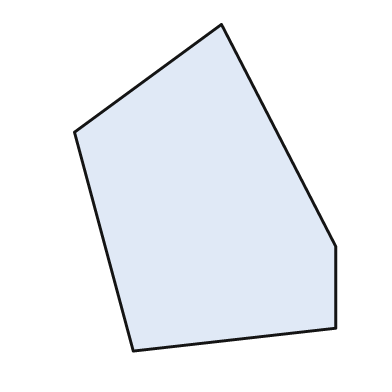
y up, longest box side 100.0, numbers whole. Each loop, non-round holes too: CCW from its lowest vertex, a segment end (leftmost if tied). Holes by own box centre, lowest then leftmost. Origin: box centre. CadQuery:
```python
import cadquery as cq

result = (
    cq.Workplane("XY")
    .moveTo(-22.0, -50.0)
    .lineTo(40.0, -43.0)
    .lineTo(40.0, -18.0)
    .lineTo(5.0, 50.0)
    .lineTo(-40.0, 17.0)
    .close()
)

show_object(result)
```